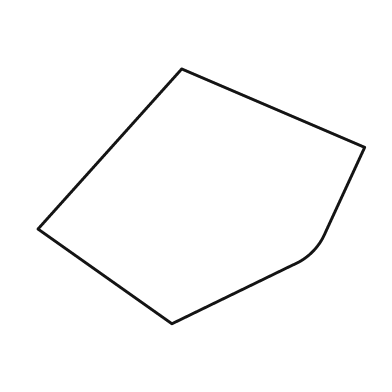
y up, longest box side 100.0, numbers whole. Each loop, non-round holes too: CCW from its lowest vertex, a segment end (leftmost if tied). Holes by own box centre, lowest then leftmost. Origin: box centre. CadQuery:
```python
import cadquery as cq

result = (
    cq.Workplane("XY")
    .moveTo(-9.0, -39.0)
    .lineTo(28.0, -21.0)
    .threePointArc((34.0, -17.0), (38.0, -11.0))
    .lineTo(50.0, 15.0)
    .lineTo(-6.0, 39.0)
    .lineTo(-50.0, -10.0)
    .close()
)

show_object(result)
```